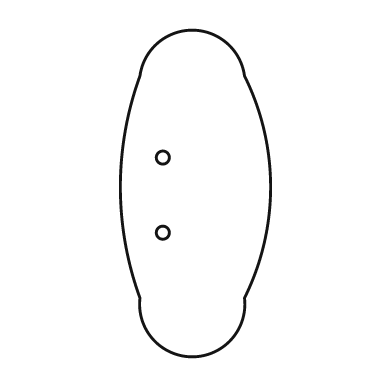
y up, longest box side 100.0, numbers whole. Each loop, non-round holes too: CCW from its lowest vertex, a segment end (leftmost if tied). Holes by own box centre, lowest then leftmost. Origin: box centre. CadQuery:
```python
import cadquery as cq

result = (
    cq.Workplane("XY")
    .moveTo(-17.0, -32.0)
    .threePointArc((-1.0, -50.0), (15.0, -32.0))
    .threePointArc((23.0, 2.0), (15.0, 36.0))
    .threePointArc((-1.0, 50.0), (-17.0, 36.0))
    .threePointArc((-23.0, 2.0), (-17.0, -32.0))
    .close()
    .moveTo(-10.0, -12.0)
    .circle(2.0)
    .moveTo(-10.0, 11.0)
    .circle(2.0)
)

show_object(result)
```